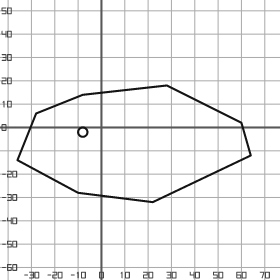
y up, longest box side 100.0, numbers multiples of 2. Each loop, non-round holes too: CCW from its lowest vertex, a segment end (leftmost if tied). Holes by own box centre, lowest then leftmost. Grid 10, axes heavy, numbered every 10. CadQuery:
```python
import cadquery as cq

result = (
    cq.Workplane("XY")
    .moveTo(22.0, -32.0)
    .lineTo(64.0, -12.0)
    .lineTo(60.0, 2.0)
    .lineTo(28.0, 18.0)
    .lineTo(-8.0, 14.0)
    .lineTo(-28.0, 6.0)
    .lineTo(-36.0, -14.0)
    .lineTo(-10.0, -28.0)
    .close()
    .moveTo(-8.0, -2.0)
    .circle(2.0)
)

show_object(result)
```